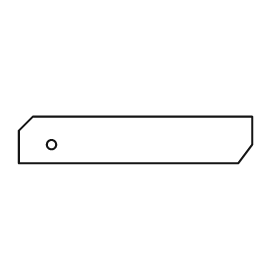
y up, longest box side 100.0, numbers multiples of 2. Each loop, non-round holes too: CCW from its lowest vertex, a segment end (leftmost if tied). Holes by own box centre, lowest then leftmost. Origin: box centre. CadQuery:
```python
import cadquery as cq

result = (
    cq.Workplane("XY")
    .moveTo(-50.0, -10.0)
    .lineTo(44.0, -10.0)
    .lineTo(50.0, -2.0)
    .lineTo(50.0, 10.0)
    .lineTo(-44.0, 10.0)
    .lineTo(-50.0, 4.0)
    .close()
    .moveTo(-36.0, -2.0)
    .circle(2.0)
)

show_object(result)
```